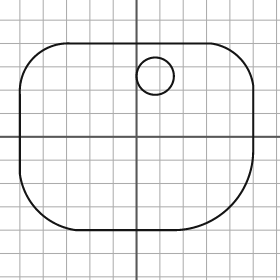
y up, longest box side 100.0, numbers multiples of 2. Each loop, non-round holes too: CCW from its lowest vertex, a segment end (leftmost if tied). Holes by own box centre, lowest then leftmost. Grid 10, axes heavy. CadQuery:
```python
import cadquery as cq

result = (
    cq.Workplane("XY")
    .moveTo(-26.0, -40.0)
    .lineTo(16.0, -40.0)
    .threePointArc((40.0, -30.0), (50.0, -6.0))
    .lineTo(50.0, 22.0)
    .threePointArc((44.0, 34.0), (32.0, 40.0))
    .lineTo(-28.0, 40.0)
    .threePointArc((-44.0, 34.0), (-50.0, 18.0))
    .lineTo(-50.0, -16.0)
    .threePointArc((-42.0, -32.0), (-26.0, -40.0))
    .close()
    .moveTo(8.0, 26.0)
    .circle(8.0)
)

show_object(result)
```